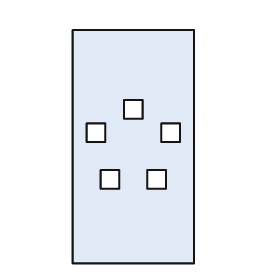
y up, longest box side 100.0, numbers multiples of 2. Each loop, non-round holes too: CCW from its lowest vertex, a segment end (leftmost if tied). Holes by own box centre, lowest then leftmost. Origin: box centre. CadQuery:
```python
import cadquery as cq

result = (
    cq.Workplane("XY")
    .moveTo(-26.0, -50.0)
    .lineTo(26.0, -50.0)
    .lineTo(26.0, 50.0)
    .lineTo(-26.0, 50.0)
    .close()
    .moveTo(-14.0, -18.0)
    .lineTo(-6.0, -18.0)
    .lineTo(-6.0, -10.0)
    .lineTo(-14.0, -10.0)
    .close()
    .moveTo(6.0, -18.0)
    .lineTo(14.0, -18.0)
    .lineTo(14.0, -10.0)
    .lineTo(6.0, -10.0)
    .close()
    .moveTo(-20.0, 2.0)
    .lineTo(-12.0, 2.0)
    .lineTo(-12.0, 10.0)
    .lineTo(-20.0, 10.0)
    .close()
    .moveTo(12.0, 2.0)
    .lineTo(20.0, 2.0)
    .lineTo(20.0, 10.0)
    .lineTo(12.0, 10.0)
    .close()
    .moveTo(-4.0, 12.0)
    .lineTo(4.0, 12.0)
    .lineTo(4.0, 20.0)
    .lineTo(-4.0, 20.0)
    .close()
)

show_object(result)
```